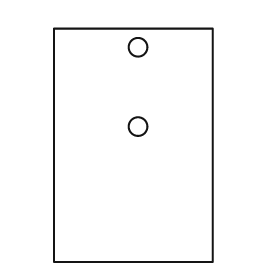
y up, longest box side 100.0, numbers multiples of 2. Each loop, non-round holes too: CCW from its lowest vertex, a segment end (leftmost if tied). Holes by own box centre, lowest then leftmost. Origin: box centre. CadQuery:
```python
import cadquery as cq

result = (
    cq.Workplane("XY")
    .moveTo(-34.0, -50.0)
    .lineTo(34.0, -50.0)
    .lineTo(34.0, 50.0)
    .lineTo(-34.0, 50.0)
    .close()
    .moveTo(2.0, 8.0)
    .circle(4.0)
    .moveTo(2.0, 42.0)
    .circle(4.0)
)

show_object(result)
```